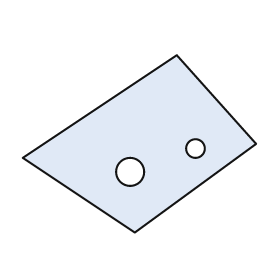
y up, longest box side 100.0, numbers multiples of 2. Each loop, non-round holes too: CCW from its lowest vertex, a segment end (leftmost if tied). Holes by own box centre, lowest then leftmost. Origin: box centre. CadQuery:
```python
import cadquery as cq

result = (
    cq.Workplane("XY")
    .moveTo(-2.0, -38.0)
    .lineTo(50.0, 0.0)
    .lineTo(16.0, 38.0)
    .lineTo(-50.0, -6.0)
    .close()
    .moveTo(-4.0, -12.0)
    .circle(6.0)
    .moveTo(24.0, -2.0)
    .circle(4.0)
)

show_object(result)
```